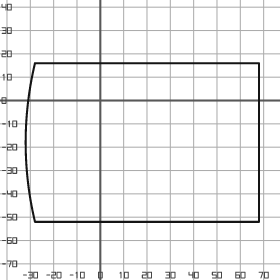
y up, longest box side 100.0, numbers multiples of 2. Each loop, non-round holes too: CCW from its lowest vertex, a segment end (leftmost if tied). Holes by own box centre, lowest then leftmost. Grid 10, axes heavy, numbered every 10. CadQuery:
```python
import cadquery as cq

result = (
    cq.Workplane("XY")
    .moveTo(-28.0, -52.0)
    .lineTo(68.0, -52.0)
    .lineTo(68.0, 16.0)
    .lineTo(-28.0, 16.0)
    .threePointArc((-32.0, -18.0), (-28.0, -52.0))
    .close()
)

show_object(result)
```